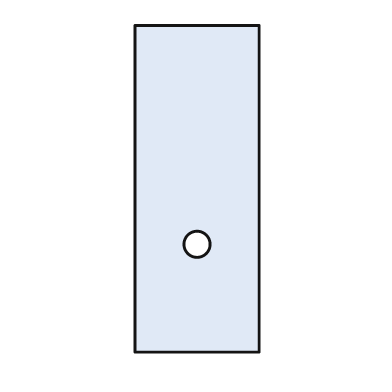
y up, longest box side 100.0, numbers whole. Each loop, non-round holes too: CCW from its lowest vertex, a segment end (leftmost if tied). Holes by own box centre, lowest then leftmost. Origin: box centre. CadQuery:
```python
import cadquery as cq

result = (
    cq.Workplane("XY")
    .moveTo(-19.0, -50.0)
    .lineTo(19.0, -50.0)
    .lineTo(19.0, 50.0)
    .lineTo(-19.0, 50.0)
    .close()
    .moveTo(0.0, -17.0)
    .circle(4.0)
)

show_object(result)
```